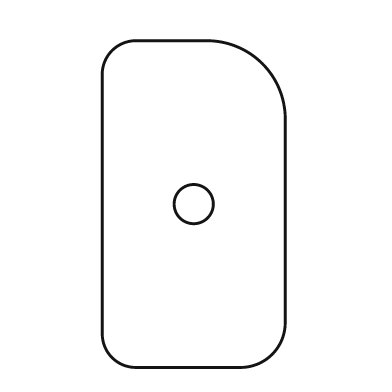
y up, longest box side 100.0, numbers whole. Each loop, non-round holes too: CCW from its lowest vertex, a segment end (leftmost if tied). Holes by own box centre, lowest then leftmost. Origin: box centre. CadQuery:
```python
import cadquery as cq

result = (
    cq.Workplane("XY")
    .moveTo(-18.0, -50.0)
    .lineTo(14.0, -50.0)
    .threePointArc((24.0, -46.0), (28.0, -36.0))
    .lineTo(28.0, 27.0)
    .threePointArc((21.0, 43.0), (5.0, 50.0))
    .lineTo(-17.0, 50.0)
    .threePointArc((-25.0, 47.0), (-28.0, 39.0))
    .lineTo(-28.0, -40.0)
    .threePointArc((-25.0, -47.0), (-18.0, -50.0))
    .close()
    .moveTo(0.0, 0.0)
    .circle(6.0)
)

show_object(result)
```